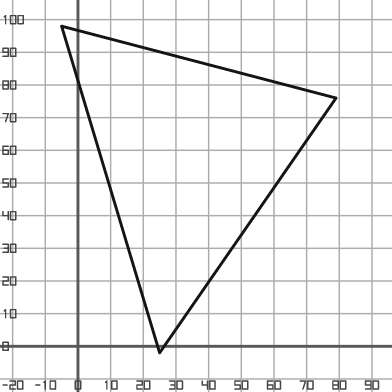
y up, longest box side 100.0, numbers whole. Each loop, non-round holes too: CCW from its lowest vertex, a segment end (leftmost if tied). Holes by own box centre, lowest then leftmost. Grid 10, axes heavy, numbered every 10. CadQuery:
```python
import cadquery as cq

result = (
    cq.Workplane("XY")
    .moveTo(25.0, -2.0)
    .lineTo(79.0, 76.0)
    .lineTo(-5.0, 98.0)
    .close()
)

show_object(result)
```